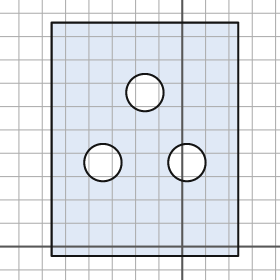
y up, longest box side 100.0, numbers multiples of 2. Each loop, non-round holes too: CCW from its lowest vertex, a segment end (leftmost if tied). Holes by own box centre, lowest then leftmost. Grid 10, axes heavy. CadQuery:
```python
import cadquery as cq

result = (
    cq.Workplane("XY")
    .moveTo(-56.0, -4.0)
    .lineTo(24.0, -4.0)
    .lineTo(24.0, 96.0)
    .lineTo(-56.0, 96.0)
    .close()
    .moveTo(-34.0, 36.0)
    .circle(8.0)
    .moveTo(2.0, 36.0)
    .circle(8.0)
    .moveTo(-16.0, 66.0)
    .circle(8.0)
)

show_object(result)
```